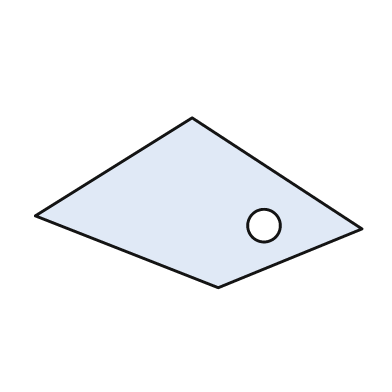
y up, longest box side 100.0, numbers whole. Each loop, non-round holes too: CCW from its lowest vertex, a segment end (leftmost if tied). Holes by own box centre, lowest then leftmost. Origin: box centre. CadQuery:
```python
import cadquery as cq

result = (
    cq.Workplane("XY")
    .moveTo(6.0, -26.0)
    .lineTo(50.0, -8.0)
    .lineTo(-2.0, 26.0)
    .lineTo(-50.0, -4.0)
    .close()
    .moveTo(20.0, -7.0)
    .circle(5.0)
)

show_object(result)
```